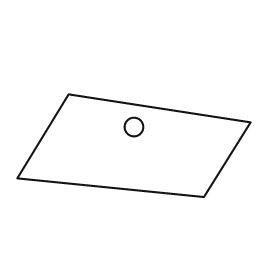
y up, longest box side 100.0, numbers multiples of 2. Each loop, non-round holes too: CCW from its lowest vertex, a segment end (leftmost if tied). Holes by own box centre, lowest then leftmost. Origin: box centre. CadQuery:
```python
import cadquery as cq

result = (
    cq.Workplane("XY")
    .moveTo(30.0, -22.0)
    .lineTo(50.0, 10.0)
    .lineTo(-28.0, 22.0)
    .lineTo(-50.0, -14.0)
    .close()
    .moveTo(0.0, 8.0)
    .circle(4.0)
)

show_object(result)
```